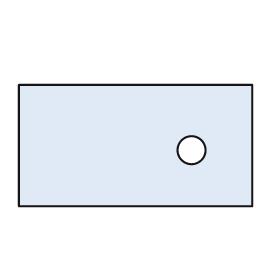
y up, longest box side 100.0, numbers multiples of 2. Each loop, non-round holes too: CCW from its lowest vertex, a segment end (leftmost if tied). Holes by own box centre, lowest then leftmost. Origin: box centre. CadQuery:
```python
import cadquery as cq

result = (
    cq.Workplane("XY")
    .moveTo(-50.0, -26.0)
    .lineTo(50.0, -26.0)
    .lineTo(50.0, 26.0)
    .lineTo(-50.0, 26.0)
    .close()
    .moveTo(24.0, -2.0)
    .circle(6.0)
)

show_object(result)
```